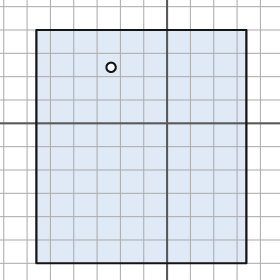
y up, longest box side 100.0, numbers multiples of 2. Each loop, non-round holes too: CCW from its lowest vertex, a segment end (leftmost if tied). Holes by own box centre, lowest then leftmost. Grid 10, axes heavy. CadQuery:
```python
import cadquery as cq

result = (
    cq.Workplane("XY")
    .moveTo(-56.0, -60.0)
    .lineTo(34.0, -60.0)
    .lineTo(34.0, 40.0)
    .lineTo(-56.0, 40.0)
    .close()
    .moveTo(-24.0, 24.0)
    .circle(2.0)
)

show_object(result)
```